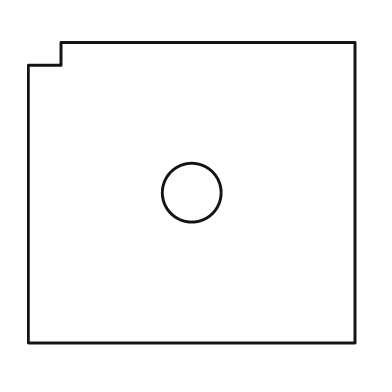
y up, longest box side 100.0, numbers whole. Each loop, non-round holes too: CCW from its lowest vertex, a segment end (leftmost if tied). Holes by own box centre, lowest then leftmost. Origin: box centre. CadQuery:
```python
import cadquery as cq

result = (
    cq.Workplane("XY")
    .moveTo(-50.0, -46.0)
    .lineTo(50.0, -46.0)
    .lineTo(50.0, 46.0)
    .lineTo(-40.0, 46.0)
    .lineTo(-40.0, 39.0)
    .lineTo(-50.0, 39.0)
    .close()
    .moveTo(0.0, 0.0)
    .circle(9.0)
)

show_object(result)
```